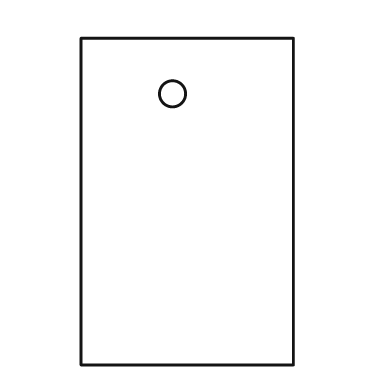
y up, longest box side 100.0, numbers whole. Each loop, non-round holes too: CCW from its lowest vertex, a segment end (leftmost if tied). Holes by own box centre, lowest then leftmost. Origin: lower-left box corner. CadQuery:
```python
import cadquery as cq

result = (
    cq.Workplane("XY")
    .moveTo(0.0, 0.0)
    .lineTo(65.0, 0.0)
    .lineTo(65.0, 100.0)
    .lineTo(0.0, 100.0)
    .close()
    .moveTo(28.0, 83.0)
    .circle(4.0)
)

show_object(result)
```